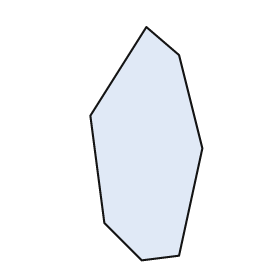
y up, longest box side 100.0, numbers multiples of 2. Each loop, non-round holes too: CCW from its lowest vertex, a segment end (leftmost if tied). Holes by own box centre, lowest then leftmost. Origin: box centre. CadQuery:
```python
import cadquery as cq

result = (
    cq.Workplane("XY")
    .moveTo(-2.0, -50.0)
    .lineTo(14.0, -48.0)
    .lineTo(24.0, -2.0)
    .lineTo(14.0, 38.0)
    .lineTo(0.0, 50.0)
    .lineTo(-24.0, 12.0)
    .lineTo(-18.0, -34.0)
    .close()
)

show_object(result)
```